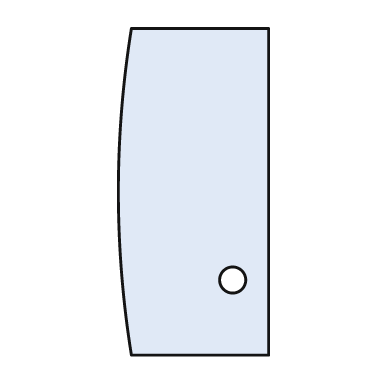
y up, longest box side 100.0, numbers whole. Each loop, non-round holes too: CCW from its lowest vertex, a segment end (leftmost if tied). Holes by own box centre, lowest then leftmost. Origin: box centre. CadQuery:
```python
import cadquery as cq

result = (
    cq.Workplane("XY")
    .moveTo(-19.0, -50.0)
    .lineTo(23.0, -50.0)
    .lineTo(23.0, 50.0)
    .lineTo(-19.0, 50.0)
    .threePointArc((-23.0, 0.0), (-19.0, -50.0))
    .close()
    .moveTo(12.0, -27.0)
    .circle(4.0)
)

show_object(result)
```